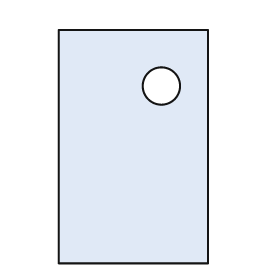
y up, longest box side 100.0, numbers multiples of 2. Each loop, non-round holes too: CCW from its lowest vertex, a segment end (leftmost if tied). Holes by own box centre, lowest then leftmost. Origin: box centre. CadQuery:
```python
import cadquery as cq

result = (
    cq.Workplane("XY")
    .moveTo(-32.0, -50.0)
    .lineTo(32.0, -50.0)
    .lineTo(32.0, 50.0)
    .lineTo(-32.0, 50.0)
    .close()
    .moveTo(12.0, 26.0)
    .circle(8.0)
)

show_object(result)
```